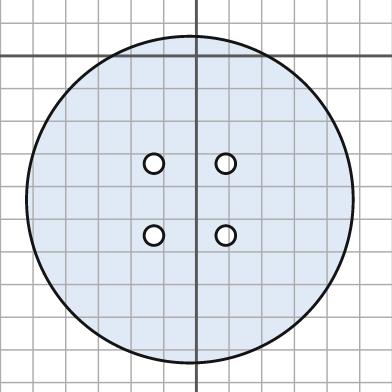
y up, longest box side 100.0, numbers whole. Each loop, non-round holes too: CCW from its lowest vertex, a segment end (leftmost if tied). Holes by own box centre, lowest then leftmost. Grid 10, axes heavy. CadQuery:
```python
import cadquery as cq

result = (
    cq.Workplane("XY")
    .moveTo(-2.0, -44.0)
    .circle(50.0)
    .moveTo(-13.0, -55.0)
    .circle(3.0)
    .moveTo(9.0, -55.0)
    .circle(3.0)
    .moveTo(-13.0, -33.0)
    .circle(3.0)
    .moveTo(9.0, -33.0)
    .circle(3.0)
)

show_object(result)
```